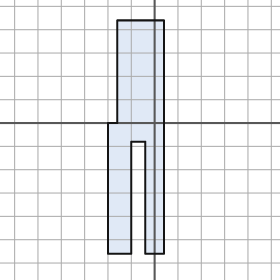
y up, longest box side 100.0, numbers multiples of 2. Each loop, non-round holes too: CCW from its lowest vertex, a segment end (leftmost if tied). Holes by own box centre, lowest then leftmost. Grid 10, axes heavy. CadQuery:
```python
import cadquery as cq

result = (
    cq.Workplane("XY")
    .moveTo(-20.0, -56.0)
    .lineTo(-10.0, -56.0)
    .lineTo(-10.0, -8.0)
    .lineTo(-4.0, -8.0)
    .lineTo(-4.0, -56.0)
    .lineTo(4.0, -56.0)
    .lineTo(4.0, 44.0)
    .lineTo(-16.0, 44.0)
    .lineTo(-16.0, 0.0)
    .lineTo(-20.0, 0.0)
    .close()
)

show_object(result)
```